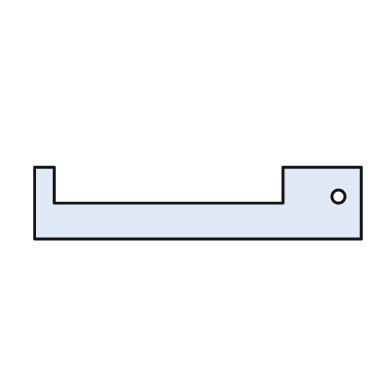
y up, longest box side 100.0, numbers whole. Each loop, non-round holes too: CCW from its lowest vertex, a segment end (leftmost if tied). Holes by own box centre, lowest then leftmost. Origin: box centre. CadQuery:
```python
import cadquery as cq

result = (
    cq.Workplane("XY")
    .moveTo(-50.0, -11.0)
    .lineTo(50.0, -11.0)
    .lineTo(50.0, 11.0)
    .lineTo(26.0, 11.0)
    .lineTo(26.0, 0.0)
    .lineTo(-44.0, 0.0)
    .lineTo(-44.0, 11.0)
    .lineTo(-50.0, 11.0)
    .close()
    .moveTo(43.0, 2.0)
    .circle(2.0)
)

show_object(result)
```